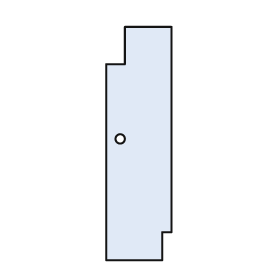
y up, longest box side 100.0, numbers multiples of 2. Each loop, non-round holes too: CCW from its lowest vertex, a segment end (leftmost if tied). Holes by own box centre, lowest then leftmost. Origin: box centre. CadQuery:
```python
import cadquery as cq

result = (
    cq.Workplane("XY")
    .moveTo(-14.0, -50.0)
    .lineTo(10.0, -50.0)
    .lineTo(10.0, -38.0)
    .lineTo(14.0, -38.0)
    .lineTo(14.0, 50.0)
    .lineTo(-6.0, 50.0)
    .lineTo(-6.0, 34.0)
    .lineTo(-14.0, 34.0)
    .close()
    .moveTo(-8.0, 2.0)
    .circle(2.0)
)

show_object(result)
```